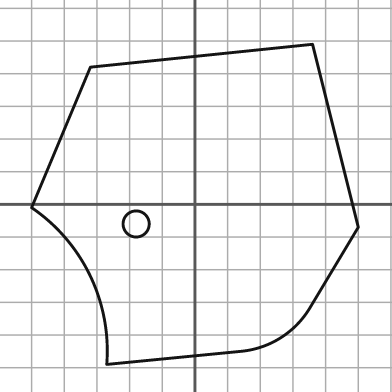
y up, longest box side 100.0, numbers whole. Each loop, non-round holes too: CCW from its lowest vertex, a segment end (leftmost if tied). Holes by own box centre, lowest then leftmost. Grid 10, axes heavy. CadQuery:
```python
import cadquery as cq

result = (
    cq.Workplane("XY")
    .moveTo(-27.0, -49.0)
    .lineTo(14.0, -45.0)
    .threePointArc((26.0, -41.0), (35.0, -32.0))
    .lineTo(50.0, -7.0)
    .lineTo(36.0, 49.0)
    .lineTo(-32.0, 42.0)
    .lineTo(-50.0, -1.0)
    .threePointArc((-32.0, -22.0), (-27.0, -49.0))
    .close()
    .moveTo(-18.0, -6.0)
    .circle(4.0)
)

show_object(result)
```